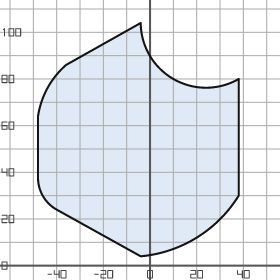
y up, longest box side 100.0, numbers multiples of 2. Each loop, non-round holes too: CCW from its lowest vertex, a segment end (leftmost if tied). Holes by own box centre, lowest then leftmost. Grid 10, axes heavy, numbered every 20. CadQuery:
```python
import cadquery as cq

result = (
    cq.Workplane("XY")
    .moveTo(-4.0, 4.0)
    .threePointArc((20.0, 12.0), (38.0, 30.0))
    .lineTo(38.0, 80.0)
    .threePointArc((10.0, 80.0), (-4.0, 104.0))
    .lineTo(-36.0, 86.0)
    .threePointArc((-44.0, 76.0), (-48.0, 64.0))
    .lineTo(-48.0, 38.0)
    .threePointArc((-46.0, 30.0), (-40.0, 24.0))
    .close()
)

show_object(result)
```